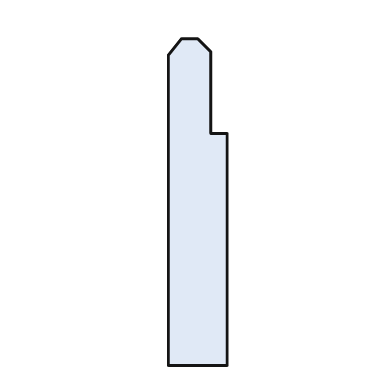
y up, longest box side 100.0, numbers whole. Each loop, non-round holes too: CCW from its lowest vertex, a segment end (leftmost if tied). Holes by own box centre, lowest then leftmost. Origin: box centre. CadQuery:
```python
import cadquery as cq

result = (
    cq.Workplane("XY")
    .moveTo(-9.0, -50.0)
    .lineTo(9.0, -50.0)
    .lineTo(9.0, 21.0)
    .lineTo(4.0, 21.0)
    .lineTo(4.0, 46.0)
    .lineTo(0.0, 50.0)
    .lineTo(-5.0, 50.0)
    .lineTo(-9.0, 45.0)
    .close()
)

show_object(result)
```